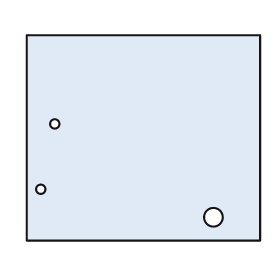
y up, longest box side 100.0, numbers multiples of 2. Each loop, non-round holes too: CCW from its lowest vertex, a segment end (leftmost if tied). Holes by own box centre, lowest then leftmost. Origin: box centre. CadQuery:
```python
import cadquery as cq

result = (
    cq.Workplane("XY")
    .moveTo(-50.0, -44.0)
    .lineTo(50.0, -44.0)
    .lineTo(50.0, 44.0)
    .lineTo(-50.0, 44.0)
    .close()
    .moveTo(30.0, -34.0)
    .circle(4.0)
    .moveTo(-44.0, -22.0)
    .circle(2.0)
    .moveTo(-38.0, 6.0)
    .circle(2.0)
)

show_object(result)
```